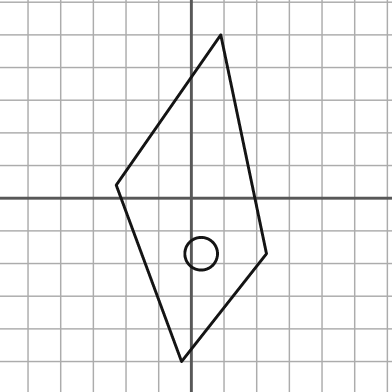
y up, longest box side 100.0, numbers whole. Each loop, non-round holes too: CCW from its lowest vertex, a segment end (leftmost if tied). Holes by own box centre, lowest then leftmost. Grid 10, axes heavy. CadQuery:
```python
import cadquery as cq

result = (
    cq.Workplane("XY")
    .moveTo(-3.0, -50.0)
    .lineTo(23.0, -17.0)
    .lineTo(9.0, 50.0)
    .lineTo(-23.0, 4.0)
    .close()
    .moveTo(3.0, -17.0)
    .circle(5.0)
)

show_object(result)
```